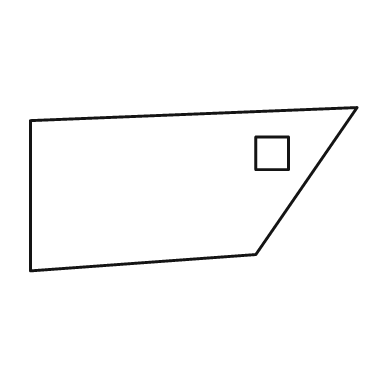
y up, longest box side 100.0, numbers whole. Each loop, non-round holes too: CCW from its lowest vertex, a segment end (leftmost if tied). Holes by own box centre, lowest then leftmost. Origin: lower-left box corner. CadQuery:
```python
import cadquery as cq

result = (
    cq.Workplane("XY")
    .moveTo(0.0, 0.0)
    .lineTo(69.0, 5.0)
    .lineTo(100.0, 50.0)
    .lineTo(0.0, 46.0)
    .close()
    .moveTo(69.0, 31.0)
    .lineTo(79.0, 31.0)
    .lineTo(79.0, 41.0)
    .lineTo(69.0, 41.0)
    .close()
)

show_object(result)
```